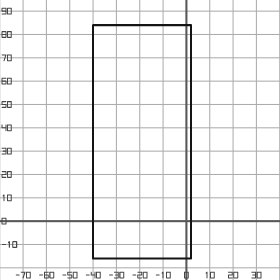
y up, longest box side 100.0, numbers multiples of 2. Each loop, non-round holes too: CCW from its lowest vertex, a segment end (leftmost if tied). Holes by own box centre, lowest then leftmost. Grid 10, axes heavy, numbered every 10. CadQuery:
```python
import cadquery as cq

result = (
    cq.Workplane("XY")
    .moveTo(-40.0, -16.0)
    .lineTo(2.0, -16.0)
    .lineTo(2.0, 84.0)
    .lineTo(-40.0, 84.0)
    .close()
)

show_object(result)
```